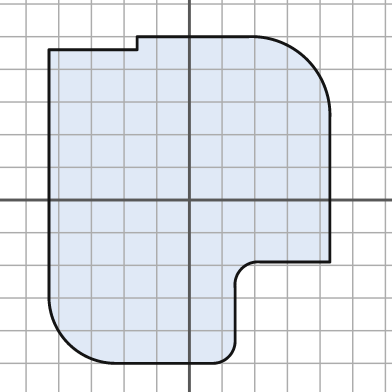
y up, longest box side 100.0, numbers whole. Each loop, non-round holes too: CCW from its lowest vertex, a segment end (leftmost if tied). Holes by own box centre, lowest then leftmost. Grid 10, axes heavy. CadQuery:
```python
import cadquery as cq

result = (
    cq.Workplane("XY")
    .moveTo(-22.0, -50.0)
    .lineTo(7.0, -50.0)
    .threePointArc((12.0, -48.0), (14.0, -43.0))
    .lineTo(14.0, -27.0)
    .threePointArc((16.0, -21.0), (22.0, -19.0))
    .lineTo(43.0, -19.0)
    .lineTo(43.0, 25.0)
    .threePointArc((36.0, 43.0), (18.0, 50.0))
    .lineTo(-16.0, 50.0)
    .lineTo(-16.0, 46.0)
    .lineTo(-43.0, 46.0)
    .lineTo(-43.0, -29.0)
    .threePointArc((-37.0, -44.0), (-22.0, -50.0))
    .close()
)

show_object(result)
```